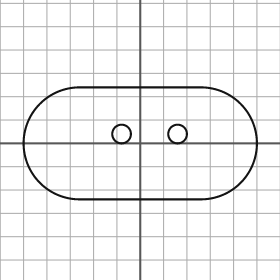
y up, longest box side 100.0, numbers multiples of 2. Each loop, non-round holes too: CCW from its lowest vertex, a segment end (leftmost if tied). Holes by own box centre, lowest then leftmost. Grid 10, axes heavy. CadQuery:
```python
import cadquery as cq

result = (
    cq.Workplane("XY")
    .moveTo(-26.0, -24.0)
    .lineTo(26.0, -24.0)
    .threePointArc((50.0, 0.0), (26.0, 24.0))
    .lineTo(-26.0, 24.0)
    .threePointArc((-50.0, 0.0), (-26.0, -24.0))
    .close()
    .moveTo(-8.0, 4.0)
    .circle(4.0)
    .moveTo(16.0, 4.0)
    .circle(4.0)
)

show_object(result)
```